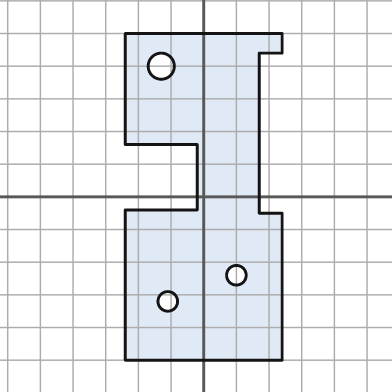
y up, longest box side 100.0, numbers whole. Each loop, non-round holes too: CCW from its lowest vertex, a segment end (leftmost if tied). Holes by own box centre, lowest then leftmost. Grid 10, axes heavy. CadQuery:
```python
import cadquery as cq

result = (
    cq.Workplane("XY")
    .moveTo(-24.0, -50.0)
    .lineTo(24.0, -50.0)
    .lineTo(24.0, -5.0)
    .lineTo(17.0, -5.0)
    .lineTo(17.0, 44.0)
    .lineTo(24.0, 44.0)
    .lineTo(24.0, 50.0)
    .lineTo(-24.0, 50.0)
    .lineTo(-24.0, 16.0)
    .lineTo(-2.0, 16.0)
    .lineTo(-2.0, -4.0)
    .lineTo(-24.0, -4.0)
    .close()
    .moveTo(-11.0, -32.0)
    .circle(3.0)
    .moveTo(10.0, -24.0)
    .circle(3.0)
    .moveTo(-13.0, 40.0)
    .circle(4.0)
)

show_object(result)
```